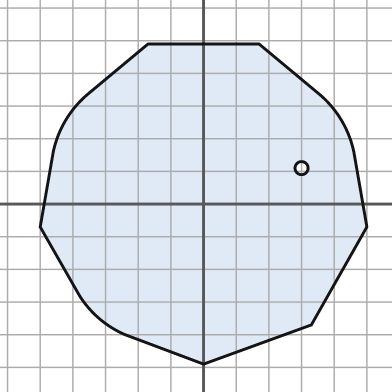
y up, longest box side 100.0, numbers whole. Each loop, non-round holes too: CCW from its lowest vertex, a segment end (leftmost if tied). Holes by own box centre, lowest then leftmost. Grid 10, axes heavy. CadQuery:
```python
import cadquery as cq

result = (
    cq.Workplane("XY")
    .moveTo(0.0, -49.0)
    .lineTo(33.0, -37.0)
    .lineTo(50.0, -7.0)
    .lineTo(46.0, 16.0)
    .threePointArc((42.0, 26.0), (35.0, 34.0))
    .lineTo(17.0, 49.0)
    .lineTo(-17.0, 49.0)
    .lineTo(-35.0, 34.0)
    .threePointArc((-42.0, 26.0), (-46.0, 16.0))
    .lineTo(-50.0, -7.0)
    .lineTo(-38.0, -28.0)
    .threePointArc((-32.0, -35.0), (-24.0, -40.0))
    .close()
    .moveTo(30.0, 11.0)
    .circle(2.0)
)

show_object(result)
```